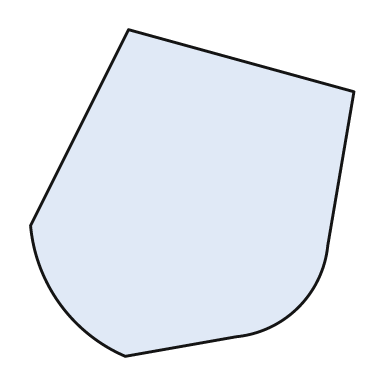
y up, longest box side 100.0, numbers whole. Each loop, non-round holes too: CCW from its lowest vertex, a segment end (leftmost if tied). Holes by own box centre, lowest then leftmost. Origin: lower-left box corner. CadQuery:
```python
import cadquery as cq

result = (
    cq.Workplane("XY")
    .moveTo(29.0, 0.0)
    .lineTo(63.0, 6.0)
    .threePointArc((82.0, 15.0), (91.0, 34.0))
    .lineTo(99.0, 81.0)
    .lineTo(30.0, 100.0)
    .lineTo(0.0, 40.0)
    .threePointArc((9.0, 16.0), (29.0, 0.0))
    .close()
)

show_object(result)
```